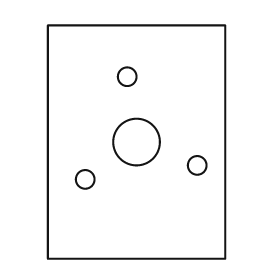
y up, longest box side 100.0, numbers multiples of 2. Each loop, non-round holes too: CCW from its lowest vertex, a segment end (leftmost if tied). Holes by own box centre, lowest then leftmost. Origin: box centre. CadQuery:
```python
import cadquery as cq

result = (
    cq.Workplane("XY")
    .moveTo(-38.0, -50.0)
    .lineTo(38.0, -50.0)
    .lineTo(38.0, 50.0)
    .lineTo(-38.0, 50.0)
    .close()
    .moveTo(-22.0, -16.0)
    .circle(4.0)
    .moveTo(26.0, -10.0)
    .circle(4.0)
    .moveTo(0.0, 0.0)
    .circle(10.0)
    .moveTo(-4.0, 28.0)
    .circle(4.0)
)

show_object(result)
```